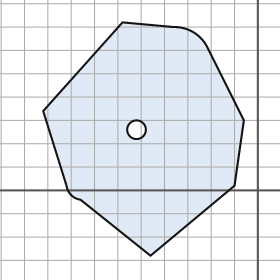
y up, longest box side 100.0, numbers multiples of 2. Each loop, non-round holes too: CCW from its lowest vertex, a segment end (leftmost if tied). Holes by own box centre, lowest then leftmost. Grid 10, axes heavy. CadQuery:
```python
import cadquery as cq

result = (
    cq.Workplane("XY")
    .moveTo(-46.0, -28.0)
    .lineTo(-10.0, 2.0)
    .lineTo(-6.0, 30.0)
    .lineTo(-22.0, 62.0)
    .threePointArc((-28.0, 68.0), (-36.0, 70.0))
    .lineTo(-58.0, 72.0)
    .lineTo(-92.0, 34.0)
    .lineTo(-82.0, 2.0)
    .threePointArc((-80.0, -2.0), (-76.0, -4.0))
    .close()
    .moveTo(-52.0, 26.0)
    .circle(4.0)
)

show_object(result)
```